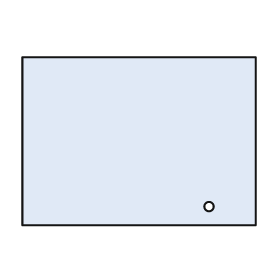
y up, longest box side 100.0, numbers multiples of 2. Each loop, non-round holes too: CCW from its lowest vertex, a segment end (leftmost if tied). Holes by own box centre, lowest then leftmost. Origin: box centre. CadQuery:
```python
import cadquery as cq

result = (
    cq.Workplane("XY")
    .moveTo(-50.0, -36.0)
    .lineTo(50.0, -36.0)
    .lineTo(50.0, 36.0)
    .lineTo(-50.0, 36.0)
    .close()
    .moveTo(30.0, -28.0)
    .circle(2.0)
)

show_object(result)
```